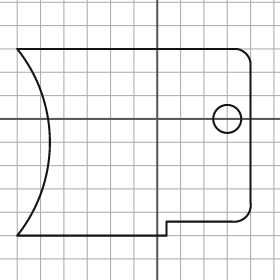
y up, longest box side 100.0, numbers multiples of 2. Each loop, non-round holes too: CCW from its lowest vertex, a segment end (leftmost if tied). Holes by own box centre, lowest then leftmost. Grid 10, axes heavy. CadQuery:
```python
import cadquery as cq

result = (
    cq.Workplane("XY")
    .moveTo(-60.0, -50.0)
    .lineTo(4.0, -50.0)
    .lineTo(4.0, -44.0)
    .lineTo(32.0, -44.0)
    .threePointArc((38.0, -42.0), (40.0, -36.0))
    .lineTo(40.0, 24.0)
    .threePointArc((38.0, 28.0), (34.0, 30.0))
    .lineTo(-60.0, 30.0)
    .threePointArc((-46.0, -10.0), (-60.0, -50.0))
    .close()
    .moveTo(30.0, 0.0)
    .circle(6.0)
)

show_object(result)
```